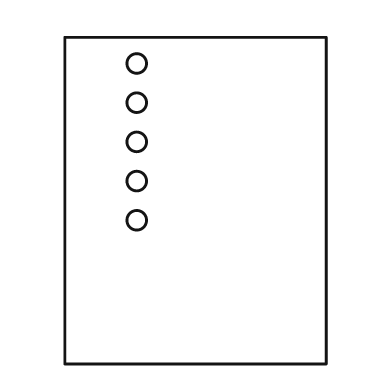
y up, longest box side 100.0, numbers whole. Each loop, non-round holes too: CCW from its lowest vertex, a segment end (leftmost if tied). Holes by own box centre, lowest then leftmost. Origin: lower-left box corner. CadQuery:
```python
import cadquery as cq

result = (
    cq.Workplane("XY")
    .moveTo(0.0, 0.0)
    .lineTo(80.0, 0.0)
    .lineTo(80.0, 100.0)
    .lineTo(0.0, 100.0)
    .close()
    .moveTo(22.0, 44.0)
    .circle(3.0)
    .moveTo(22.0, 56.0)
    .circle(3.0)
    .moveTo(22.0, 68.0)
    .circle(3.0)
    .moveTo(22.0, 80.0)
    .circle(3.0)
    .moveTo(22.0, 92.0)
    .circle(3.0)
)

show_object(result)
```